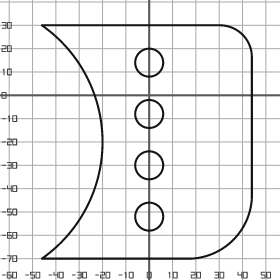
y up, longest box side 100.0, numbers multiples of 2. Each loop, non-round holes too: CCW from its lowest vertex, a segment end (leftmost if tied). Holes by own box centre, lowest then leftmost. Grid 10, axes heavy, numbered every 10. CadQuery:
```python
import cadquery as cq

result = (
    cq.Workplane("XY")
    .moveTo(-46.0, -70.0)
    .lineTo(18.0, -70.0)
    .threePointArc((36.0, -62.0), (44.0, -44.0))
    .lineTo(44.0, 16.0)
    .threePointArc((40.0, 26.0), (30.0, 30.0))
    .lineTo(-46.0, 30.0)
    .threePointArc((-20.0, -20.0), (-46.0, -70.0))
    .close()
    .moveTo(0.0, -52.0)
    .circle(6.0)
    .moveTo(0.0, -30.0)
    .circle(6.0)
    .moveTo(0.0, -8.0)
    .circle(6.0)
    .moveTo(0.0, 14.0)
    .circle(6.0)
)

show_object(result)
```